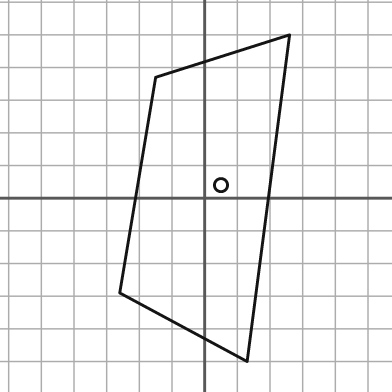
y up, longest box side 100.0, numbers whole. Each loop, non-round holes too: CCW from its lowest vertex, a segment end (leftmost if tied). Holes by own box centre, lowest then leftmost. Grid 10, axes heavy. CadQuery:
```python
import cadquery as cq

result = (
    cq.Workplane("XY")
    .moveTo(13.0, -50.0)
    .lineTo(26.0, 50.0)
    .lineTo(-15.0, 37.0)
    .lineTo(-26.0, -29.0)
    .close()
    .moveTo(5.0, 4.0)
    .circle(2.0)
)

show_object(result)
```